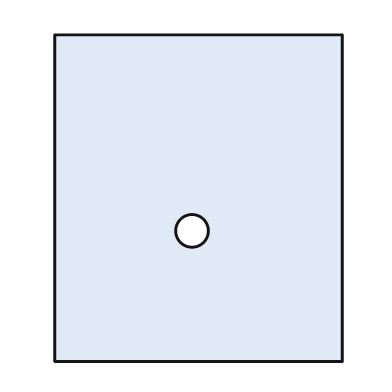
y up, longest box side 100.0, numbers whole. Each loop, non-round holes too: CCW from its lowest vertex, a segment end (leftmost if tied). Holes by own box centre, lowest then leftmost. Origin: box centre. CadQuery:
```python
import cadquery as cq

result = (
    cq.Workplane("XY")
    .moveTo(-44.0, -50.0)
    .lineTo(44.0, -50.0)
    .lineTo(44.0, 50.0)
    .lineTo(-44.0, 50.0)
    .close()
    .moveTo(-2.0, -10.0)
    .circle(5.0)
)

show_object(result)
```